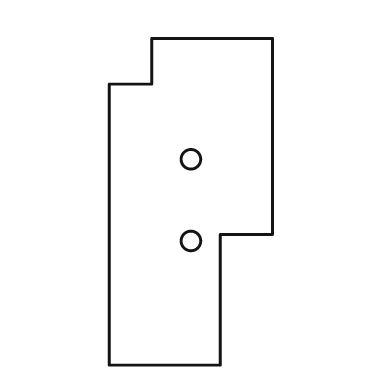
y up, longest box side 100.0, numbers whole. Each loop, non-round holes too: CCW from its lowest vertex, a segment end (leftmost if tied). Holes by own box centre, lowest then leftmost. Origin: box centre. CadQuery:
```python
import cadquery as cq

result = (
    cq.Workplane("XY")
    .moveTo(-25.0, -50.0)
    .lineTo(9.0, -50.0)
    .lineTo(9.0, -10.0)
    .lineTo(25.0, -10.0)
    .lineTo(25.0, 50.0)
    .lineTo(-12.0, 50.0)
    .lineTo(-12.0, 36.0)
    .lineTo(-25.0, 36.0)
    .close()
    .moveTo(0.0, -12.0)
    .circle(3.0)
    .moveTo(0.0, 13.0)
    .circle(3.0)
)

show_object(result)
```